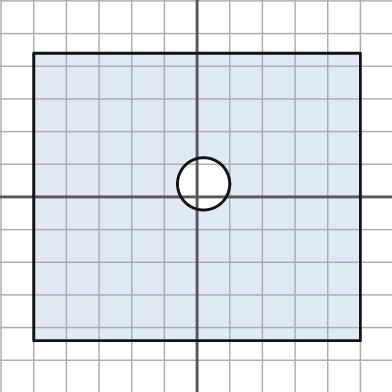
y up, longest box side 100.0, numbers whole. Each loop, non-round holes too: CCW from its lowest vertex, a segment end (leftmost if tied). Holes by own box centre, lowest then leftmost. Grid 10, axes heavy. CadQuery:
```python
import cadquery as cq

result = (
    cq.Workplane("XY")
    .moveTo(-50.0, -44.0)
    .lineTo(50.0, -44.0)
    .lineTo(50.0, 44.0)
    .lineTo(-50.0, 44.0)
    .close()
    .moveTo(2.0, 4.0)
    .circle(8.0)
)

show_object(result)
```